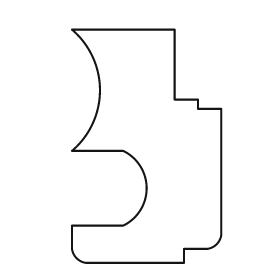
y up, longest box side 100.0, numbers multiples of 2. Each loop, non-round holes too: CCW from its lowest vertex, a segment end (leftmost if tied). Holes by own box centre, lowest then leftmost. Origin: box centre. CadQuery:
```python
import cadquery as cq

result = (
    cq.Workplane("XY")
    .moveTo(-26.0, -50.0)
    .lineTo(16.0, -50.0)
    .lineTo(16.0, -44.0)
    .lineTo(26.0, -44.0)
    .threePointArc((30.0, -42.0), (32.0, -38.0))
    .lineTo(32.0, 16.0)
    .lineTo(22.0, 16.0)
    .lineTo(22.0, 20.0)
    .lineTo(12.0, 20.0)
    .lineTo(12.0, 50.0)
    .lineTo(-32.0, 50.0)
    .threePointArc((-20.0, 24.0), (-32.0, -2.0))
    .lineTo(-10.0, -2.0)
    .threePointArc((0.0, -18.0), (-10.0, -34.0))
    .lineTo(-32.0, -34.0)
    .lineTo(-32.0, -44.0)
    .threePointArc((-30.0, -48.0), (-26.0, -50.0))
    .close()
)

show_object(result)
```